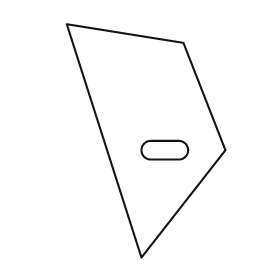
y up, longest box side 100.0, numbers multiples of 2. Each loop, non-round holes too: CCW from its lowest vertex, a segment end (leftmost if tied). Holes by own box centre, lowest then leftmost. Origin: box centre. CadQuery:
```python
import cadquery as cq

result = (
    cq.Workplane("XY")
    .moveTo(-2.0, -50.0)
    .lineTo(34.0, -4.0)
    .lineTo(16.0, 42.0)
    .lineTo(-34.0, 50.0)
    .close()
    .moveTo(2.0, -8.0)
    .lineTo(14.0, -8.0)
    .threePointArc((18.0, -4.0), (14.0, 0.0))
    .lineTo(2.0, 0.0)
    .threePointArc((-2.0, -4.0), (2.0, -8.0))
    .close()
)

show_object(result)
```